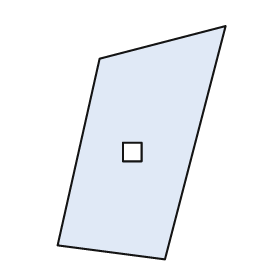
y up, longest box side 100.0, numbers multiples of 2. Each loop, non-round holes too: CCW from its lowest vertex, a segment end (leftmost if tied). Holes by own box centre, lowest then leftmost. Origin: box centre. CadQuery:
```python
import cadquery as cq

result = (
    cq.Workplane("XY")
    .moveTo(10.0, -50.0)
    .lineTo(36.0, 50.0)
    .lineTo(-18.0, 36.0)
    .lineTo(-36.0, -44.0)
    .close()
    .moveTo(-8.0, -8.0)
    .lineTo(0.0, -8.0)
    .lineTo(0.0, 0.0)
    .lineTo(-8.0, 0.0)
    .close()
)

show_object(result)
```